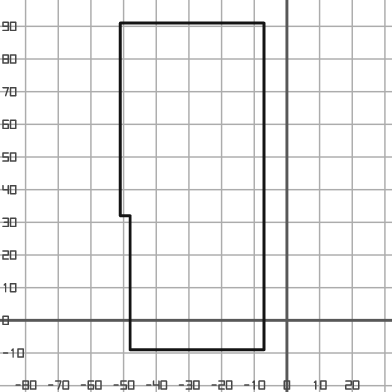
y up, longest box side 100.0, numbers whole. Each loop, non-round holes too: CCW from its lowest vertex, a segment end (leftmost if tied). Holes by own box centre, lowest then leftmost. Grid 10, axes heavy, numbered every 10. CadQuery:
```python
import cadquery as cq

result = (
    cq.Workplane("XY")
    .moveTo(-48.0, -9.0)
    .lineTo(-7.0, -9.0)
    .lineTo(-7.0, 91.0)
    .lineTo(-51.0, 91.0)
    .lineTo(-51.0, 32.0)
    .lineTo(-48.0, 32.0)
    .close()
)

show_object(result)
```